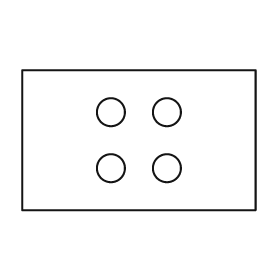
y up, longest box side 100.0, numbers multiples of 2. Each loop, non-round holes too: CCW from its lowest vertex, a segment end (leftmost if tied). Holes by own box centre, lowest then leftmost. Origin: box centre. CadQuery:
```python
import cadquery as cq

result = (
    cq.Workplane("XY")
    .moveTo(-50.0, -30.0)
    .lineTo(50.0, -30.0)
    .lineTo(50.0, 30.0)
    .lineTo(-50.0, 30.0)
    .close()
    .moveTo(-12.0, -12.0)
    .circle(6.0)
    .moveTo(12.0, -12.0)
    .circle(6.0)
    .moveTo(-12.0, 12.0)
    .circle(6.0)
    .moveTo(12.0, 12.0)
    .circle(6.0)
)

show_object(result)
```